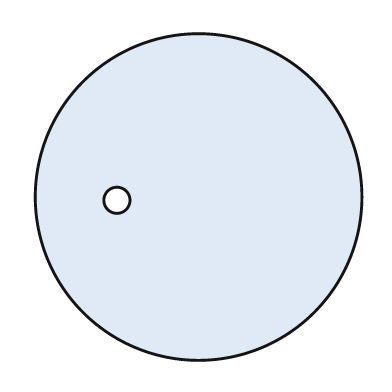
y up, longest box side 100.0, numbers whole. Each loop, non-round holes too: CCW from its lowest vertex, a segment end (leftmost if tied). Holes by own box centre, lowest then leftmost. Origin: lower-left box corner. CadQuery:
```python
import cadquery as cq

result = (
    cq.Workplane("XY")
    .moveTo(50.0, 50.0)
    .circle(50.0)
    .moveTo(25.0, 49.0)
    .circle(4.0)
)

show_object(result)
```